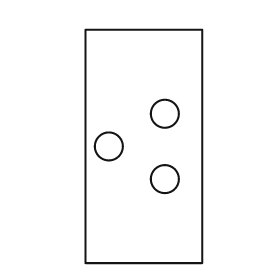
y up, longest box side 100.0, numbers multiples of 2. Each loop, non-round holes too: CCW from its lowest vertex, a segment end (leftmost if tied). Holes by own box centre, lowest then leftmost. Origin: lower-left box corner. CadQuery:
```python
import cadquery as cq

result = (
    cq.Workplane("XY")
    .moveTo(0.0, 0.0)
    .lineTo(50.0, 0.0)
    .lineTo(50.0, 100.0)
    .lineTo(0.0, 100.0)
    .close()
    .moveTo(34.0, 36.0)
    .circle(6.0)
    .moveTo(10.0, 50.0)
    .circle(6.0)
    .moveTo(34.0, 64.0)
    .circle(6.0)
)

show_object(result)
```